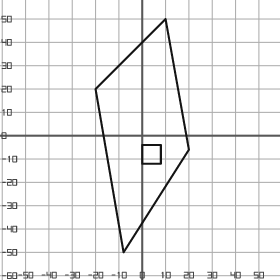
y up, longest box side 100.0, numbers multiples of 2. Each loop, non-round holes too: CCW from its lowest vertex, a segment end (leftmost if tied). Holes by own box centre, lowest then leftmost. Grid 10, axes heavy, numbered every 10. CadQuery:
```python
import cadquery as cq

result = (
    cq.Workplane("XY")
    .moveTo(-8.0, -50.0)
    .lineTo(20.0, -6.0)
    .lineTo(10.0, 50.0)
    .lineTo(-20.0, 20.0)
    .close()
    .moveTo(0.0, -12.0)
    .lineTo(8.0, -12.0)
    .lineTo(8.0, -4.0)
    .lineTo(0.0, -4.0)
    .close()
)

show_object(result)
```